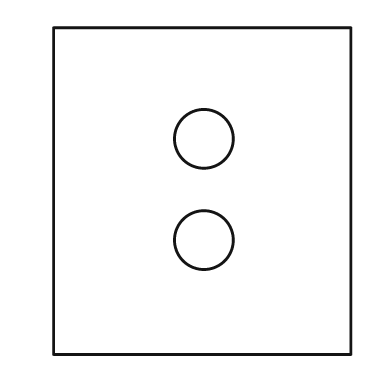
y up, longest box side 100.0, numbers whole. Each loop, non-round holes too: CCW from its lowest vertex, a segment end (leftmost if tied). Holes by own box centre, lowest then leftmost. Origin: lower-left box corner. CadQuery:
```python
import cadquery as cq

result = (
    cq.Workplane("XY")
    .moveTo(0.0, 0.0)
    .lineTo(91.0, 0.0)
    .lineTo(91.0, 100.0)
    .lineTo(0.0, 100.0)
    .close()
    .moveTo(46.0, 35.0)
    .circle(9.0)
    .moveTo(46.0, 66.0)
    .circle(9.0)
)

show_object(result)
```